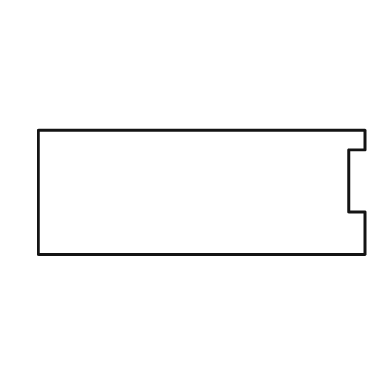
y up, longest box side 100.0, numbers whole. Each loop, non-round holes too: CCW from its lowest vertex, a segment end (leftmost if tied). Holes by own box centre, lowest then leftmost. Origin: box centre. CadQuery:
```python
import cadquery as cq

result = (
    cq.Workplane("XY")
    .moveTo(-50.0, -19.0)
    .lineTo(50.0, -19.0)
    .lineTo(50.0, -6.0)
    .lineTo(45.0, -6.0)
    .lineTo(45.0, 13.0)
    .lineTo(50.0, 13.0)
    .lineTo(50.0, 19.0)
    .lineTo(-50.0, 19.0)
    .close()
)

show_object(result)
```